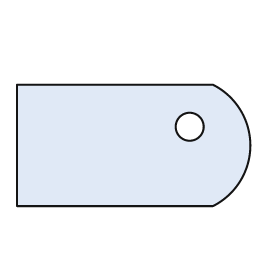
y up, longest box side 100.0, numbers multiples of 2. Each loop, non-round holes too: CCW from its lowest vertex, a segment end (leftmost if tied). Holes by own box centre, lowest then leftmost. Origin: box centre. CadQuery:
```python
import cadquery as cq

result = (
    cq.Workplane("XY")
    .moveTo(-50.0, -26.0)
    .lineTo(34.0, -26.0)
    .threePointArc((50.0, 0.0), (34.0, 26.0))
    .lineTo(-50.0, 26.0)
    .close()
    .moveTo(24.0, 8.0)
    .circle(6.0)
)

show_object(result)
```